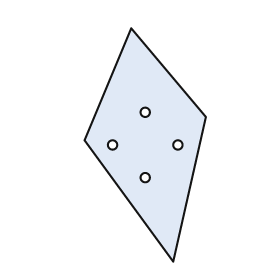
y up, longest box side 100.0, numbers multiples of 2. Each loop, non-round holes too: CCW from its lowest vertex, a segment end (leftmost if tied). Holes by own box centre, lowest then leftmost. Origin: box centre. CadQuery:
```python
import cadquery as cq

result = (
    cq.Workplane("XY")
    .moveTo(12.0, -50.0)
    .lineTo(26.0, 12.0)
    .lineTo(-6.0, 50.0)
    .lineTo(-26.0, 2.0)
    .close()
    .moveTo(0.0, -14.0)
    .circle(2.0)
    .moveTo(-14.0, 0.0)
    .circle(2.0)
    .moveTo(14.0, 0.0)
    .circle(2.0)
    .moveTo(0.0, 14.0)
    .circle(2.0)
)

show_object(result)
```